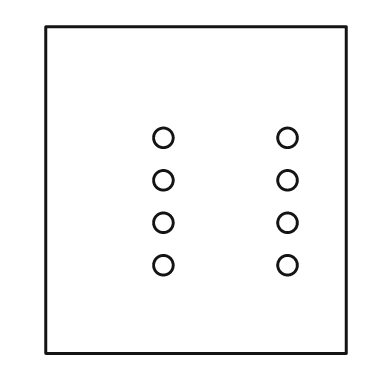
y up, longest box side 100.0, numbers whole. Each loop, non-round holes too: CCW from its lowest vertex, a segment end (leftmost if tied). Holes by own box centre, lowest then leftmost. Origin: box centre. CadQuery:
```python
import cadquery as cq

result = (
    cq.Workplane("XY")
    .moveTo(-46.0, -50.0)
    .lineTo(46.0, -50.0)
    .lineTo(46.0, 50.0)
    .lineTo(-46.0, 50.0)
    .close()
    .moveTo(-10.0, -23.0)
    .circle(3.0)
    .moveTo(28.0, -23.0)
    .circle(3.0)
    .moveTo(-10.0, -10.0)
    .circle(3.0)
    .moveTo(28.0, -10.0)
    .circle(3.0)
    .moveTo(-10.0, 3.0)
    .circle(3.0)
    .moveTo(28.0, 3.0)
    .circle(3.0)
    .moveTo(-10.0, 16.0)
    .circle(3.0)
    .moveTo(28.0, 16.0)
    .circle(3.0)
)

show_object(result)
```